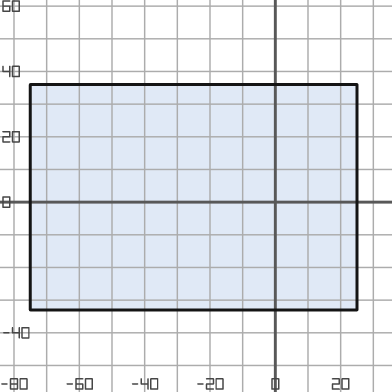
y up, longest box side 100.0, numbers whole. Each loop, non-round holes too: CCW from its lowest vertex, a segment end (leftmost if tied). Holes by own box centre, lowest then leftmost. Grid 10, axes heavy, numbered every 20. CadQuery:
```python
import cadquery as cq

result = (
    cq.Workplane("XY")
    .moveTo(-75.0, -33.0)
    .lineTo(25.0, -33.0)
    .lineTo(25.0, 36.0)
    .lineTo(-75.0, 36.0)
    .close()
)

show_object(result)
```